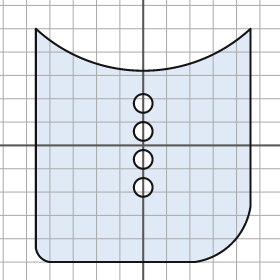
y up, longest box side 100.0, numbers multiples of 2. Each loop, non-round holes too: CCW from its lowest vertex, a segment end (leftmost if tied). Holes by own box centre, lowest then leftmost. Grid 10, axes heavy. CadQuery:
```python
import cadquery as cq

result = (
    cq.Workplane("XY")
    .moveTo(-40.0, -50.0)
    .lineTo(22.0, -50.0)
    .threePointArc((38.0, -42.0), (46.0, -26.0))
    .lineTo(46.0, 50.0)
    .threePointArc((0.0, 32.0), (-46.0, 50.0))
    .lineTo(-46.0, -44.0)
    .threePointArc((-44.0, -48.0), (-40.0, -50.0))
    .close()
    .moveTo(0.0, -18.0)
    .circle(4.0)
    .moveTo(0.0, -6.0)
    .circle(4.0)
    .moveTo(0.0, 6.0)
    .circle(4.0)
    .moveTo(0.0, 18.0)
    .circle(4.0)
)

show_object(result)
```